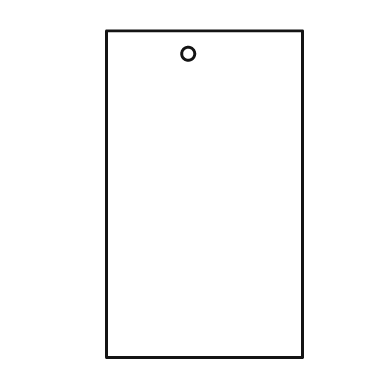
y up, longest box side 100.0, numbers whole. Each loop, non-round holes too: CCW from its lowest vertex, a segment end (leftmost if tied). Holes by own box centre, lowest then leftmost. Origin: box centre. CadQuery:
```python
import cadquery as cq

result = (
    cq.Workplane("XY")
    .moveTo(-30.0, -50.0)
    .lineTo(30.0, -50.0)
    .lineTo(30.0, 50.0)
    .lineTo(-30.0, 50.0)
    .close()
    .moveTo(-5.0, 43.0)
    .circle(2.0)
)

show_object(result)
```